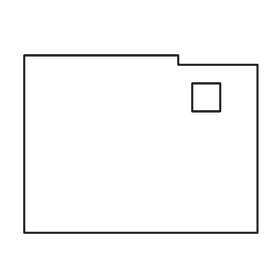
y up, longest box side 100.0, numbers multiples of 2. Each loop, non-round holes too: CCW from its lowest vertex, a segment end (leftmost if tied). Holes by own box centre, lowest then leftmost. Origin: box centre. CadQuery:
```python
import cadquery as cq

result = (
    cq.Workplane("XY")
    .moveTo(-50.0, -38.0)
    .lineTo(50.0, -38.0)
    .lineTo(50.0, 34.0)
    .lineTo(16.0, 34.0)
    .lineTo(16.0, 38.0)
    .lineTo(-50.0, 38.0)
    .close()
    .moveTo(22.0, 14.0)
    .lineTo(34.0, 14.0)
    .lineTo(34.0, 26.0)
    .lineTo(22.0, 26.0)
    .close()
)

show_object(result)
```